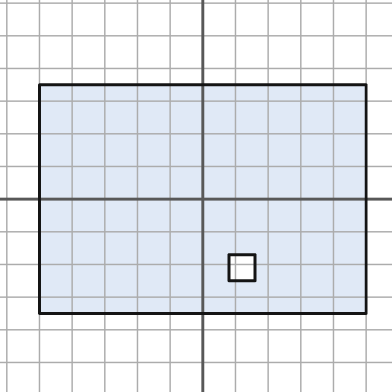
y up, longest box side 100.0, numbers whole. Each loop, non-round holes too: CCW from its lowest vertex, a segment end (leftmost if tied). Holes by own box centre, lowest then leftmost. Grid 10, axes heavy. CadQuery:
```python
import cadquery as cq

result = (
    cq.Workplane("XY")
    .moveTo(-50.0, -35.0)
    .lineTo(50.0, -35.0)
    .lineTo(50.0, 35.0)
    .lineTo(-50.0, 35.0)
    .close()
    .moveTo(8.0, -25.0)
    .lineTo(16.0, -25.0)
    .lineTo(16.0, -17.0)
    .lineTo(8.0, -17.0)
    .close()
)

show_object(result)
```